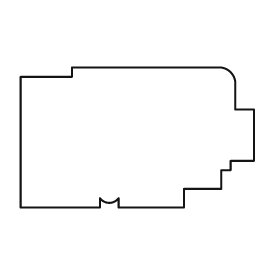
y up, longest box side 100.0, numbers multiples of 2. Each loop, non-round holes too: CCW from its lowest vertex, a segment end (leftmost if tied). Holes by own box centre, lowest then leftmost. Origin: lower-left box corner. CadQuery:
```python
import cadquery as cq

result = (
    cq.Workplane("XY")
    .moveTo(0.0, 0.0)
    .lineTo(34.0, 0.0)
    .lineTo(34.0, 4.0)
    .threePointArc((38.0, 2.0), (42.0, 4.0))
    .lineTo(42.0, 0.0)
    .lineTo(70.0, 0.0)
    .lineTo(70.0, 8.0)
    .lineTo(86.0, 8.0)
    .lineTo(86.0, 16.0)
    .lineTo(90.0, 16.0)
    .lineTo(90.0, 20.0)
    .lineTo(100.0, 20.0)
    .lineTo(100.0, 42.0)
    .lineTo(92.0, 42.0)
    .lineTo(92.0, 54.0)
    .threePointArc((90.0, 58.0), (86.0, 60.0))
    .lineTo(22.0, 60.0)
    .lineTo(22.0, 56.0)
    .lineTo(0.0, 56.0)
    .close()
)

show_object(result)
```